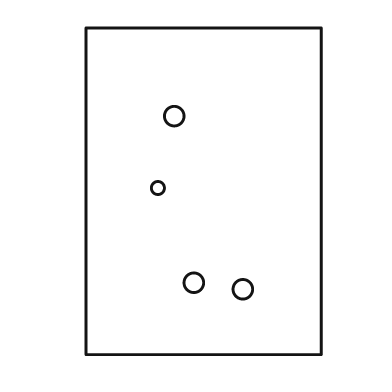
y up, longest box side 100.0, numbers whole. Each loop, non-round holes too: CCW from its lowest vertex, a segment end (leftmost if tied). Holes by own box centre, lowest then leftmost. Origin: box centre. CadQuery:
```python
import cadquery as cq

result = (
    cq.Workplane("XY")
    .moveTo(-36.0, -50.0)
    .lineTo(36.0, -50.0)
    .lineTo(36.0, 50.0)
    .lineTo(-36.0, 50.0)
    .close()
    .moveTo(12.0, -30.0)
    .circle(3.0)
    .moveTo(-3.0, -28.0)
    .circle(3.0)
    .moveTo(-14.0, 1.0)
    .circle(2.0)
    .moveTo(-9.0, 23.0)
    .circle(3.0)
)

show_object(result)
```